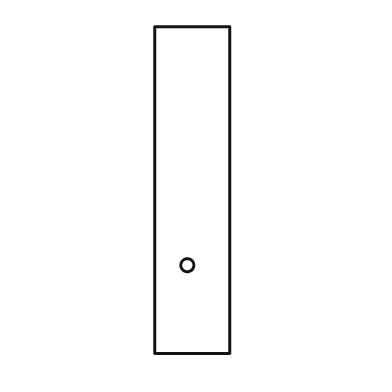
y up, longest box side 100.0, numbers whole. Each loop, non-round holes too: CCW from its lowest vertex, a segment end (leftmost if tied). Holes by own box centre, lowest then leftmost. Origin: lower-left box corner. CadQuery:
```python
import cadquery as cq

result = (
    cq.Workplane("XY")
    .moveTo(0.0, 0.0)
    .lineTo(23.0, 0.0)
    .lineTo(23.0, 100.0)
    .lineTo(0.0, 100.0)
    .close()
    .moveTo(10.0, 27.0)
    .circle(2.0)
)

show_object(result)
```